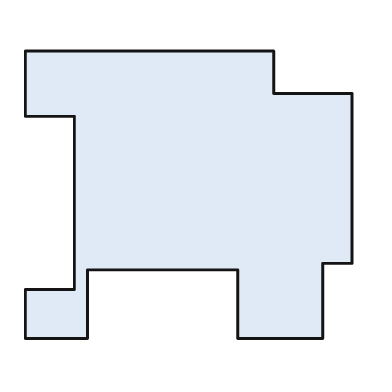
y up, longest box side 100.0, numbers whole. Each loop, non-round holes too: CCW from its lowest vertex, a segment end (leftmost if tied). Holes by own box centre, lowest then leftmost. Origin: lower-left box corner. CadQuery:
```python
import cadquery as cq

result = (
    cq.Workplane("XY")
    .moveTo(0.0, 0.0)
    .lineTo(19.0, 0.0)
    .lineTo(19.0, 21.0)
    .lineTo(65.0, 21.0)
    .lineTo(65.0, 0.0)
    .lineTo(91.0, 0.0)
    .lineTo(91.0, 23.0)
    .lineTo(100.0, 23.0)
    .lineTo(100.0, 75.0)
    .lineTo(76.0, 75.0)
    .lineTo(76.0, 88.0)
    .lineTo(0.0, 88.0)
    .lineTo(0.0, 68.0)
    .lineTo(15.0, 68.0)
    .lineTo(15.0, 15.0)
    .lineTo(0.0, 15.0)
    .close()
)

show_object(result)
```